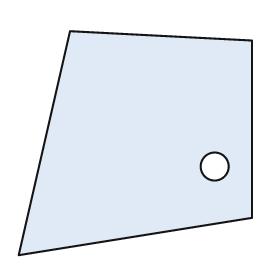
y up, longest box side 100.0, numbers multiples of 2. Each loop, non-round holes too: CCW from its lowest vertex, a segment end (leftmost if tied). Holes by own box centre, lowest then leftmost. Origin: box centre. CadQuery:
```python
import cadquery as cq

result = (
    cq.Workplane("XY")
    .moveTo(-50.0, -48.0)
    .lineTo(50.0, -32.0)
    .lineTo(50.0, 44.0)
    .lineTo(-28.0, 48.0)
    .close()
    .moveTo(34.0, -10.0)
    .circle(6.0)
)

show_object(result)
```